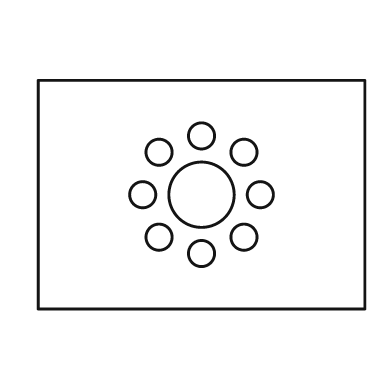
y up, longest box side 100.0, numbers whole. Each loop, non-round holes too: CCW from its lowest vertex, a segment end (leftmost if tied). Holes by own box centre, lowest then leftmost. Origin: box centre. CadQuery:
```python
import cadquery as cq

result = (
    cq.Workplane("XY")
    .moveTo(-50.0, -35.0)
    .lineTo(50.0, -35.0)
    .lineTo(50.0, 35.0)
    .lineTo(-50.0, 35.0)
    .close()
    .moveTo(0.0, -18.0)
    .circle(4.0)
    .moveTo(-13.0, -13.0)
    .circle(4.0)
    .moveTo(13.0, -13.0)
    .circle(4.0)
    .moveTo(-18.0, 0.0)
    .circle(4.0)
    .moveTo(0.0, 0.0)
    .circle(10.0)
    .moveTo(18.0, 0.0)
    .circle(4.0)
    .moveTo(-13.0, 13.0)
    .circle(4.0)
    .moveTo(13.0, 13.0)
    .circle(4.0)
    .moveTo(0.0, 18.0)
    .circle(4.0)
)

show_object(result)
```